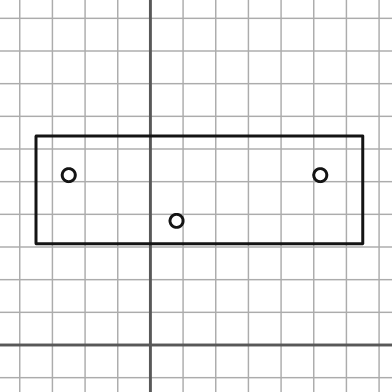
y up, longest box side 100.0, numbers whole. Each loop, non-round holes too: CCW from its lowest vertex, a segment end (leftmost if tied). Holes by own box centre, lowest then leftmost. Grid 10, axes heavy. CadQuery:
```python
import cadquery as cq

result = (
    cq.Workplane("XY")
    .moveTo(-35.0, 31.0)
    .lineTo(65.0, 31.0)
    .lineTo(65.0, 64.0)
    .lineTo(-35.0, 64.0)
    .close()
    .moveTo(8.0, 38.0)
    .circle(2.0)
    .moveTo(-25.0, 52.0)
    .circle(2.0)
    .moveTo(52.0, 52.0)
    .circle(2.0)
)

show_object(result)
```